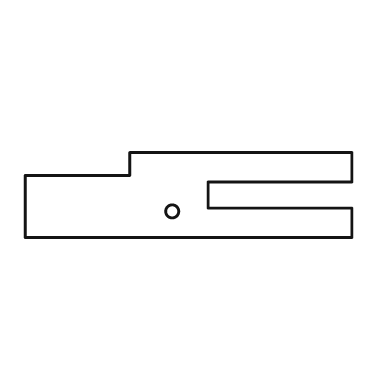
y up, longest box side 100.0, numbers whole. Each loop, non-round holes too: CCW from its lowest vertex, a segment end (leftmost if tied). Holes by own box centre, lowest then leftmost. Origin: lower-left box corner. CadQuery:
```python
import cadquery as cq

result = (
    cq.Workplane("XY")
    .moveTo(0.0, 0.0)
    .lineTo(100.0, 0.0)
    .lineTo(100.0, 9.0)
    .lineTo(56.0, 9.0)
    .lineTo(56.0, 17.0)
    .lineTo(100.0, 17.0)
    .lineTo(100.0, 26.0)
    .lineTo(32.0, 26.0)
    .lineTo(32.0, 19.0)
    .lineTo(0.0, 19.0)
    .close()
    .moveTo(45.0, 8.0)
    .circle(2.0)
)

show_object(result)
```